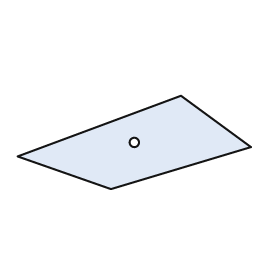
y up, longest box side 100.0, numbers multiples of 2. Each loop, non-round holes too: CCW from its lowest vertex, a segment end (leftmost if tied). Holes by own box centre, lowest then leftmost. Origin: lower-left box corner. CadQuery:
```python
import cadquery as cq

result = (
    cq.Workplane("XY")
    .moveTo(40.0, 0.0)
    .lineTo(100.0, 18.0)
    .lineTo(70.0, 40.0)
    .lineTo(0.0, 14.0)
    .close()
    .moveTo(50.0, 20.0)
    .circle(2.0)
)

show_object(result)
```